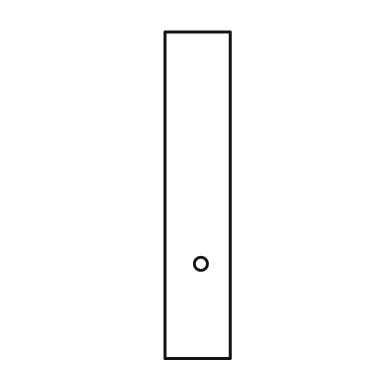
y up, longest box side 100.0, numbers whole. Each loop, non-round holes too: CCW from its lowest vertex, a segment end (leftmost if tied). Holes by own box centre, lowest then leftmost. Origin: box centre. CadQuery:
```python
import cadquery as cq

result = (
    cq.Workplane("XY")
    .moveTo(-10.0, -50.0)
    .lineTo(10.0, -50.0)
    .lineTo(10.0, 50.0)
    .lineTo(-10.0, 50.0)
    .close()
    .moveTo(1.0, -21.0)
    .circle(2.0)
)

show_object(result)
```